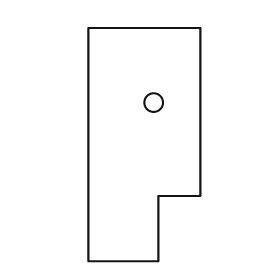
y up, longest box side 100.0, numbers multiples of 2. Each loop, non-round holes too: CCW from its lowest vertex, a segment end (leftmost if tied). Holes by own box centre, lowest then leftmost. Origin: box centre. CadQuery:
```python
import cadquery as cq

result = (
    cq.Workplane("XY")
    .moveTo(-24.0, -50.0)
    .lineTo(6.0, -50.0)
    .lineTo(6.0, -22.0)
    .lineTo(24.0, -22.0)
    .lineTo(24.0, 50.0)
    .lineTo(-24.0, 50.0)
    .close()
    .moveTo(4.0, 18.0)
    .circle(4.0)
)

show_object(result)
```